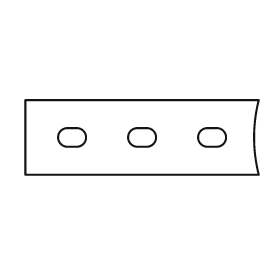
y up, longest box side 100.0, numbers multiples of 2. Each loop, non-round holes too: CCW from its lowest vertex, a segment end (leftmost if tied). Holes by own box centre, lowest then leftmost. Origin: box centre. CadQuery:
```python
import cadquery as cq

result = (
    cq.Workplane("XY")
    .moveTo(-50.0, -16.0)
    .lineTo(50.0, -16.0)
    .threePointArc((48.0, 0.0), (50.0, 16.0))
    .lineTo(-50.0, 16.0)
    .close()
    .moveTo(-32.0, -4.0)
    .lineTo(-28.0, -4.0)
    .threePointArc((-24.0, 0.0), (-28.0, 4.0))
    .lineTo(-32.0, 4.0)
    .threePointArc((-36.0, 0.0), (-32.0, -4.0))
    .close()
    .moveTo(-2.0, -4.0)
    .lineTo(2.0, -4.0)
    .threePointArc((6.0, 0.0), (2.0, 4.0))
    .lineTo(-2.0, 4.0)
    .threePointArc((-6.0, 0.0), (-2.0, -4.0))
    .close()
    .moveTo(28.0, -4.0)
    .lineTo(32.0, -4.0)
    .threePointArc((36.0, 0.0), (32.0, 4.0))
    .lineTo(28.0, 4.0)
    .threePointArc((24.0, 0.0), (28.0, -4.0))
    .close()
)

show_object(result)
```